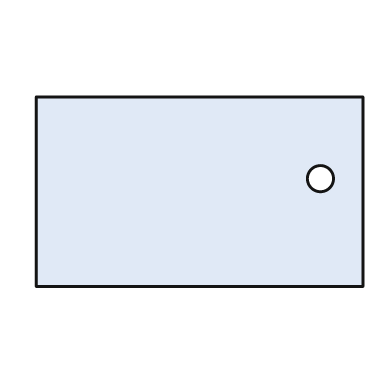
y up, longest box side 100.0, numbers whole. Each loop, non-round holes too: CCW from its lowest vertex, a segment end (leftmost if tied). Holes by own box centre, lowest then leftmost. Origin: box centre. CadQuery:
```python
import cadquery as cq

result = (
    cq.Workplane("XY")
    .moveTo(-50.0, -29.0)
    .lineTo(50.0, -29.0)
    .lineTo(50.0, 29.0)
    .lineTo(-50.0, 29.0)
    .close()
    .moveTo(37.0, 4.0)
    .circle(4.0)
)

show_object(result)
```